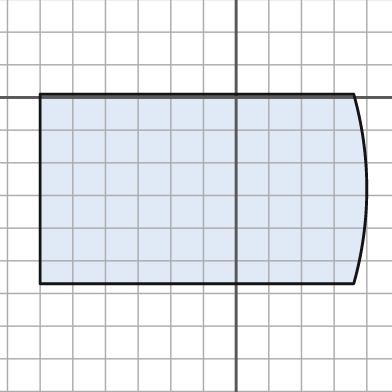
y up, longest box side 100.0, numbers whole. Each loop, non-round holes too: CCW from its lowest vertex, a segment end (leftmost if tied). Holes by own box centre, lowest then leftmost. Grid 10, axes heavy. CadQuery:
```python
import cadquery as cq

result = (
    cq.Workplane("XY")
    .moveTo(-60.0, -57.0)
    .lineTo(36.0, -57.0)
    .threePointArc((40.0, -28.0), (36.0, 1.0))
    .lineTo(-60.0, 1.0)
    .close()
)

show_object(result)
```